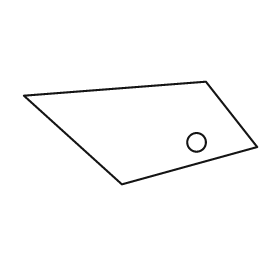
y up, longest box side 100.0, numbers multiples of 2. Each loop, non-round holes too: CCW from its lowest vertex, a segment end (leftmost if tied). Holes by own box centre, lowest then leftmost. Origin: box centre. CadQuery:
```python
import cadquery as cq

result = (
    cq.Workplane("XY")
    .moveTo(-8.0, -22.0)
    .lineTo(50.0, -6.0)
    .lineTo(28.0, 22.0)
    .lineTo(-50.0, 16.0)
    .close()
    .moveTo(24.0, -4.0)
    .circle(4.0)
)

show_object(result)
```